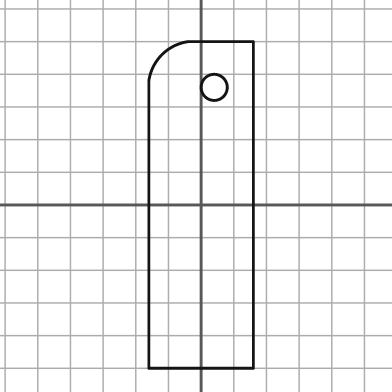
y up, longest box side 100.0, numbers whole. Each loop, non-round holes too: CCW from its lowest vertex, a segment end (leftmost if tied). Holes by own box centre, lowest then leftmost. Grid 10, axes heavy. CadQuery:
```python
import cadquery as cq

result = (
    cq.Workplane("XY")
    .moveTo(-16.0, -50.0)
    .lineTo(16.0, -50.0)
    .lineTo(16.0, 50.0)
    .lineTo(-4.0, 50.0)
    .threePointArc((-12.0, 46.0), (-16.0, 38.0))
    .close()
    .moveTo(4.0, 36.0)
    .circle(4.0)
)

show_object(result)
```